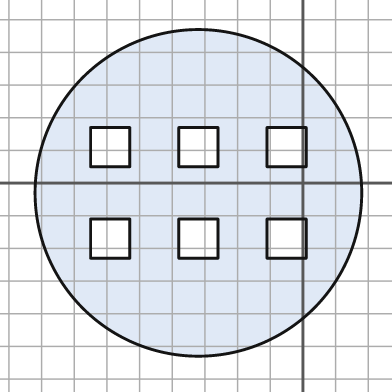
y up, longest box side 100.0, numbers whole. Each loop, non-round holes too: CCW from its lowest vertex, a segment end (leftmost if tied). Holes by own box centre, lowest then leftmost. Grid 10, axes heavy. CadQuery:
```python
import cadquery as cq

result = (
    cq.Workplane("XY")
    .moveTo(-32.0, -3.0)
    .circle(50.0)
    .moveTo(-65.0, -23.0)
    .lineTo(-53.0, -23.0)
    .lineTo(-53.0, -11.0)
    .lineTo(-65.0, -11.0)
    .close()
    .moveTo(-38.0, -23.0)
    .lineTo(-26.0, -23.0)
    .lineTo(-26.0, -11.0)
    .lineTo(-38.0, -11.0)
    .close()
    .moveTo(-11.0, -23.0)
    .lineTo(1.0, -23.0)
    .lineTo(1.0, -11.0)
    .lineTo(-11.0, -11.0)
    .close()
    .moveTo(-65.0, 5.0)
    .lineTo(-53.0, 5.0)
    .lineTo(-53.0, 17.0)
    .lineTo(-65.0, 17.0)
    .close()
    .moveTo(-38.0, 5.0)
    .lineTo(-26.0, 5.0)
    .lineTo(-26.0, 17.0)
    .lineTo(-38.0, 17.0)
    .close()
    .moveTo(-11.0, 5.0)
    .lineTo(1.0, 5.0)
    .lineTo(1.0, 17.0)
    .lineTo(-11.0, 17.0)
    .close()
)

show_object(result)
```